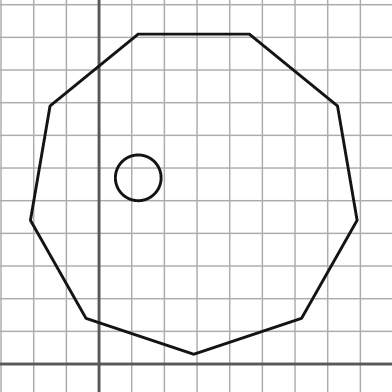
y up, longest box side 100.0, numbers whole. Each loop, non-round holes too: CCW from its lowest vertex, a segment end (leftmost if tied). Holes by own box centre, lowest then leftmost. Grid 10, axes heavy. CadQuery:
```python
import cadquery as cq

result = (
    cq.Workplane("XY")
    .moveTo(29.0, 3.0)
    .lineTo(62.0, 14.0)
    .lineTo(79.0, 44.0)
    .lineTo(73.0, 79.0)
    .lineTo(46.0, 101.0)
    .lineTo(12.0, 101.0)
    .lineTo(-15.0, 79.0)
    .lineTo(-21.0, 44.0)
    .lineTo(-4.0, 14.0)
    .close()
    .moveTo(12.0, 57.0)
    .circle(7.0)
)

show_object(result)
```